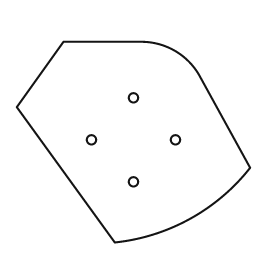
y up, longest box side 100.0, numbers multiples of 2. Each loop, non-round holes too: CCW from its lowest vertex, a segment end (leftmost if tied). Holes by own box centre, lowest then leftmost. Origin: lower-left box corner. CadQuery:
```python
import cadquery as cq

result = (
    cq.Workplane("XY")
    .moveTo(42.0, 0.0)
    .threePointArc((74.0, 10.0), (100.0, 32.0))
    .lineTo(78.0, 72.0)
    .threePointArc((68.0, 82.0), (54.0, 86.0))
    .lineTo(20.0, 86.0)
    .lineTo(0.0, 58.0)
    .close()
    .moveTo(50.0, 26.0)
    .circle(2.0)
    .moveTo(32.0, 44.0)
    .circle(2.0)
    .moveTo(68.0, 44.0)
    .circle(2.0)
    .moveTo(50.0, 62.0)
    .circle(2.0)
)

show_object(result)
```